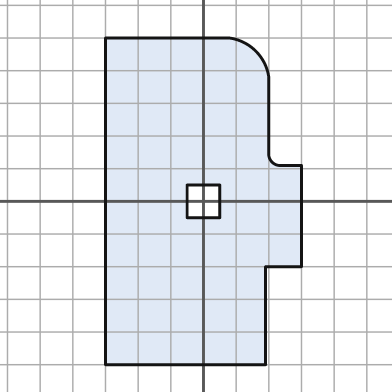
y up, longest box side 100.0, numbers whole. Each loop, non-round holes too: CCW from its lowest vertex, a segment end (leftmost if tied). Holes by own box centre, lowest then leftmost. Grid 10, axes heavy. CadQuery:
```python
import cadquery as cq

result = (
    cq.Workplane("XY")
    .moveTo(-30.0, -50.0)
    .lineTo(19.0, -50.0)
    .lineTo(19.0, -20.0)
    .lineTo(30.0, -20.0)
    .lineTo(30.0, 11.0)
    .lineTo(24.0, 11.0)
    .threePointArc((21.0, 12.0), (20.0, 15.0))
    .lineTo(20.0, 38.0)
    .threePointArc((16.0, 46.0), (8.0, 50.0))
    .lineTo(-30.0, 50.0)
    .close()
    .moveTo(-5.0, -5.0)
    .lineTo(5.0, -5.0)
    .lineTo(5.0, 5.0)
    .lineTo(-5.0, 5.0)
    .close()
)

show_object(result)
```